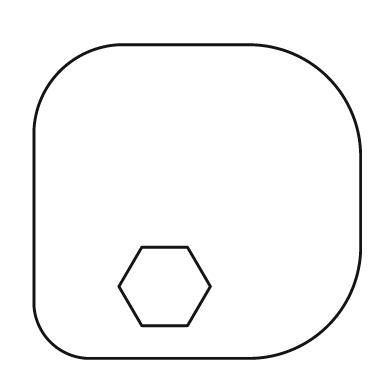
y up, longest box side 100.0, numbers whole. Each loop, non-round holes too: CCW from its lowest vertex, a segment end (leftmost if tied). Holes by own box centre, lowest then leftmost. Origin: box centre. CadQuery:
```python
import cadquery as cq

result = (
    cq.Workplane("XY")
    .moveTo(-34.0, -48.0)
    .lineTo(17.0, -48.0)
    .threePointArc((40.0, -38.0), (50.0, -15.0))
    .lineTo(50.0, 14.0)
    .threePointArc((40.0, 38.0), (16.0, 48.0))
    .lineTo(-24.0, 48.0)
    .threePointArc((-42.0, 40.0), (-50.0, 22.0))
    .lineTo(-50.0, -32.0)
    .threePointArc((-45.0, -43.0), (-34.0, -48.0))
    .close()
    .moveTo(-17.0, -38.0)
    .lineTo(-3.0, -38.0)
    .lineTo(4.0, -26.0)
    .lineTo(-3.0, -14.0)
    .lineTo(-17.0, -14.0)
    .lineTo(-24.0, -26.0)
    .close()
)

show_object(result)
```